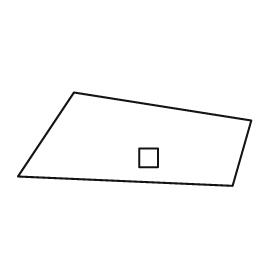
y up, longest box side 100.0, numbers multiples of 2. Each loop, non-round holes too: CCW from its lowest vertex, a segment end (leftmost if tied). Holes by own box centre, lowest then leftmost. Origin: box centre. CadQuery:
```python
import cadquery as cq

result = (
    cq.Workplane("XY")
    .moveTo(42.0, -20.0)
    .lineTo(50.0, 8.0)
    .lineTo(-26.0, 20.0)
    .lineTo(-50.0, -16.0)
    .close()
    .moveTo(2.0, -12.0)
    .lineTo(10.0, -12.0)
    .lineTo(10.0, -4.0)
    .lineTo(2.0, -4.0)
    .close()
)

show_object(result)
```